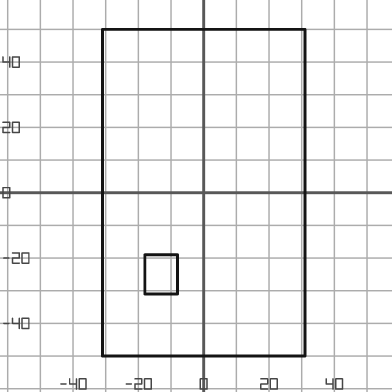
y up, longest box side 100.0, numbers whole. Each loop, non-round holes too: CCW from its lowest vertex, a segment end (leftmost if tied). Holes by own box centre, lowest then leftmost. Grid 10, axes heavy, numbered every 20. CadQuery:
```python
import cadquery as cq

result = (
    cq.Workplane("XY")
    .moveTo(-31.0, -50.0)
    .lineTo(31.0, -50.0)
    .lineTo(31.0, 50.0)
    .lineTo(-31.0, 50.0)
    .close()
    .moveTo(-18.0, -31.0)
    .lineTo(-8.0, -31.0)
    .lineTo(-8.0, -19.0)
    .lineTo(-18.0, -19.0)
    .close()
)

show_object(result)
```